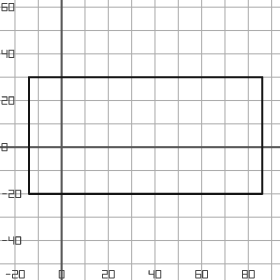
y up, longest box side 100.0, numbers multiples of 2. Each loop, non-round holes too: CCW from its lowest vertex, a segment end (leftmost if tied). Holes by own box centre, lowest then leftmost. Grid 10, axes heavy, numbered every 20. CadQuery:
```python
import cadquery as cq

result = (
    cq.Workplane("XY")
    .moveTo(-14.0, -20.0)
    .lineTo(86.0, -20.0)
    .lineTo(86.0, 30.0)
    .lineTo(-14.0, 30.0)
    .close()
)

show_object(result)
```